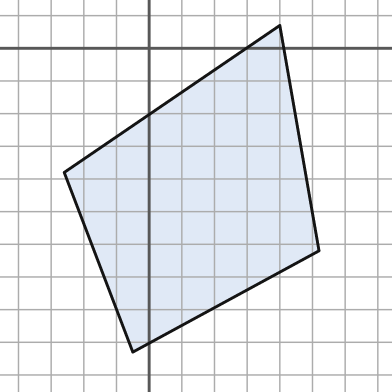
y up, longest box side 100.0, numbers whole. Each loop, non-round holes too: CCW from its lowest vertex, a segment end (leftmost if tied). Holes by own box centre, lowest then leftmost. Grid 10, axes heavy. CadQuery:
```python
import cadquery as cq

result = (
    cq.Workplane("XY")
    .moveTo(-5.0, -93.0)
    .lineTo(52.0, -62.0)
    .lineTo(40.0, 7.0)
    .lineTo(-26.0, -38.0)
    .close()
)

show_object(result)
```